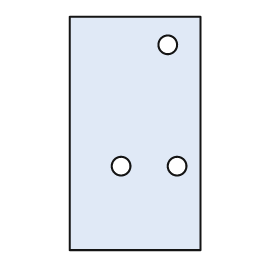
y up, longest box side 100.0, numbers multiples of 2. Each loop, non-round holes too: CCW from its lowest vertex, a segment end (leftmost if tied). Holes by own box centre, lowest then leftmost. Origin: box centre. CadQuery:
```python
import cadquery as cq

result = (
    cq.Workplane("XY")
    .moveTo(-28.0, -50.0)
    .lineTo(28.0, -50.0)
    .lineTo(28.0, 50.0)
    .lineTo(-28.0, 50.0)
    .close()
    .moveTo(-6.0, -14.0)
    .circle(4.0)
    .moveTo(18.0, -14.0)
    .circle(4.0)
    .moveTo(14.0, 38.0)
    .circle(4.0)
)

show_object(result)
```